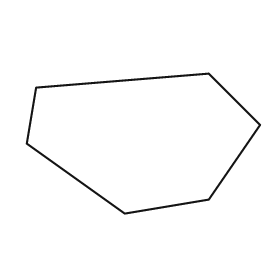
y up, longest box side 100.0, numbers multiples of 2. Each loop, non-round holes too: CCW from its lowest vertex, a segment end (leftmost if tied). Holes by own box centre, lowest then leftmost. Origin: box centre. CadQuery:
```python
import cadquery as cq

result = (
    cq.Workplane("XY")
    .moveTo(-8.0, -30.0)
    .lineTo(28.0, -24.0)
    .lineTo(50.0, 8.0)
    .lineTo(28.0, 30.0)
    .lineTo(-46.0, 24.0)
    .lineTo(-50.0, 0.0)
    .close()
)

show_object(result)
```